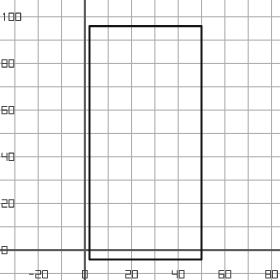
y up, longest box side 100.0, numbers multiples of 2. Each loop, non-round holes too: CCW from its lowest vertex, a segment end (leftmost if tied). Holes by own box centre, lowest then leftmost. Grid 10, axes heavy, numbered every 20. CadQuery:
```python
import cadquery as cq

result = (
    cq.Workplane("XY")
    .moveTo(2.0, -4.0)
    .lineTo(50.0, -4.0)
    .lineTo(50.0, 96.0)
    .lineTo(2.0, 96.0)
    .close()
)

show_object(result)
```